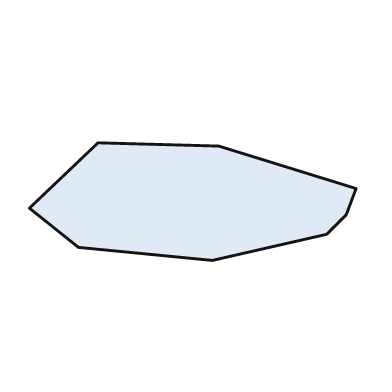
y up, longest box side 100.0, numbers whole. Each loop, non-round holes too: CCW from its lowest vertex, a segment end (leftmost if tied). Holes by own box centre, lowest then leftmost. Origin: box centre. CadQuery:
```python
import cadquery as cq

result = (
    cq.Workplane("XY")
    .moveTo(6.0, -18.0)
    .lineTo(41.0, -10.0)
    .lineTo(47.0, -4.0)
    .lineTo(50.0, 4.0)
    .lineTo(8.0, 17.0)
    .lineTo(-29.0, 18.0)
    .lineTo(-50.0, -2.0)
    .lineTo(-35.0, -14.0)
    .close()
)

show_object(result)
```